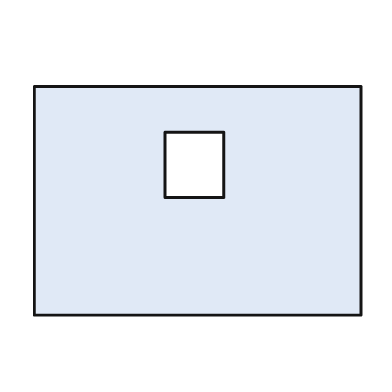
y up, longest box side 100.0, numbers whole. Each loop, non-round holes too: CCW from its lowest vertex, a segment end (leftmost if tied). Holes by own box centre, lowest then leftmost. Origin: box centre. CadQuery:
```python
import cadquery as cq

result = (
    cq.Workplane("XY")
    .moveTo(-50.0, -35.0)
    .lineTo(50.0, -35.0)
    .lineTo(50.0, 35.0)
    .lineTo(-50.0, 35.0)
    .close()
    .moveTo(-10.0, 1.0)
    .lineTo(8.0, 1.0)
    .lineTo(8.0, 21.0)
    .lineTo(-10.0, 21.0)
    .close()
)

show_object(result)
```